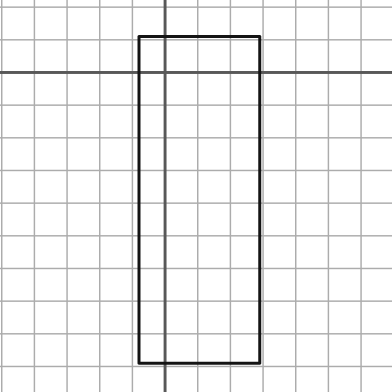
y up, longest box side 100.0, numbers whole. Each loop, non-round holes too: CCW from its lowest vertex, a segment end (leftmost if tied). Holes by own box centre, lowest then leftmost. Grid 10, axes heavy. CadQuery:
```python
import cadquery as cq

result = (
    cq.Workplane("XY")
    .moveTo(-8.0, -89.0)
    .lineTo(29.0, -89.0)
    .lineTo(29.0, 11.0)
    .lineTo(-8.0, 11.0)
    .close()
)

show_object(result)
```